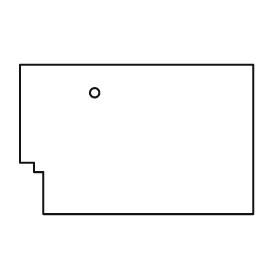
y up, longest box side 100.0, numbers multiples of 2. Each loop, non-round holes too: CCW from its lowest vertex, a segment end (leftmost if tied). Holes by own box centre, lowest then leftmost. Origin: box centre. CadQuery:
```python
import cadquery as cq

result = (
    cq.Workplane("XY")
    .moveTo(-40.0, -32.0)
    .lineTo(50.0, -32.0)
    .lineTo(50.0, 32.0)
    .lineTo(-50.0, 32.0)
    .lineTo(-50.0, -10.0)
    .lineTo(-44.0, -10.0)
    .lineTo(-44.0, -14.0)
    .lineTo(-40.0, -14.0)
    .close()
    .moveTo(-18.0, 20.0)
    .circle(2.0)
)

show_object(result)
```